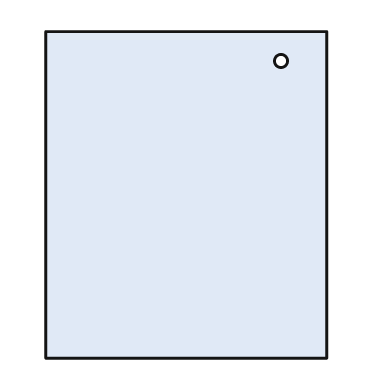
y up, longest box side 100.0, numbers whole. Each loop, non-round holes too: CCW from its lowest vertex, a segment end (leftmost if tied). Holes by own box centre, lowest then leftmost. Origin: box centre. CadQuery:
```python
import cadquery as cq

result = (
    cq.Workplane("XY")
    .moveTo(-43.0, -50.0)
    .lineTo(43.0, -50.0)
    .lineTo(43.0, 50.0)
    .lineTo(-43.0, 50.0)
    .close()
    .moveTo(29.0, 41.0)
    .circle(2.0)
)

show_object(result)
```